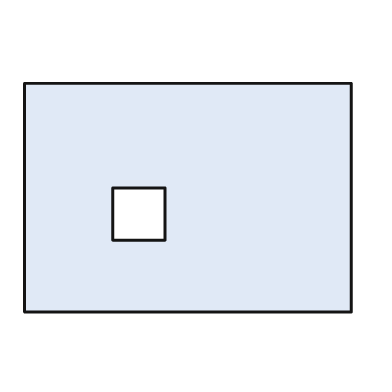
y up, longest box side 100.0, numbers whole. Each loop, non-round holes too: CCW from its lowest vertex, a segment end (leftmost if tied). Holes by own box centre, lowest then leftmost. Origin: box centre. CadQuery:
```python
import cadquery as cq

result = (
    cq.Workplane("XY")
    .moveTo(-50.0, -35.0)
    .lineTo(50.0, -35.0)
    .lineTo(50.0, 35.0)
    .lineTo(-50.0, 35.0)
    .close()
    .moveTo(-23.0, -13.0)
    .lineTo(-7.0, -13.0)
    .lineTo(-7.0, 3.0)
    .lineTo(-23.0, 3.0)
    .close()
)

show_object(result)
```